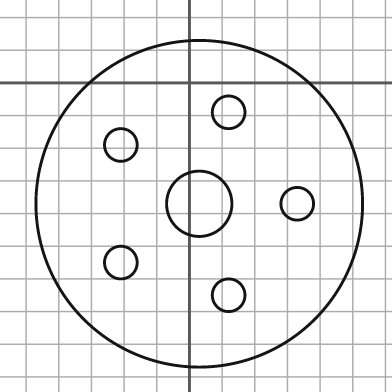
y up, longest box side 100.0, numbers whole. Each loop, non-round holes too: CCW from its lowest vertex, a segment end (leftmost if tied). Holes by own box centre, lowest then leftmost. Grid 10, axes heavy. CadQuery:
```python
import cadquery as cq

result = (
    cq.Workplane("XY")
    .moveTo(3.0, -37.0)
    .circle(50.0)
    .moveTo(12.0, -65.0)
    .circle(5.0)
    .moveTo(-21.0, -55.0)
    .circle(5.0)
    .moveTo(3.0, -37.0)
    .circle(10.0)
    .moveTo(33.0, -37.0)
    .circle(5.0)
    .moveTo(-21.0, -19.0)
    .circle(5.0)
    .moveTo(12.0, -9.0)
    .circle(5.0)
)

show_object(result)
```